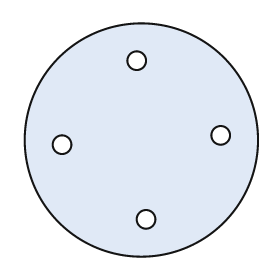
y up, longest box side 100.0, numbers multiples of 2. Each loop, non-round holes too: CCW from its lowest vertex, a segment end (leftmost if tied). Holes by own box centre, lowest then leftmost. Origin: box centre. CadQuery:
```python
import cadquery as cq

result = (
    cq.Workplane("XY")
    .moveTo(0.0, 0.0)
    .circle(50.0)
    .moveTo(2.0, -34.0)
    .circle(4.0)
    .moveTo(-34.0, -2.0)
    .circle(4.0)
    .moveTo(34.0, 2.0)
    .circle(4.0)
    .moveTo(-2.0, 34.0)
    .circle(4.0)
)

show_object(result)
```